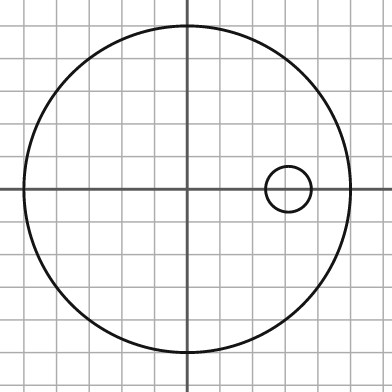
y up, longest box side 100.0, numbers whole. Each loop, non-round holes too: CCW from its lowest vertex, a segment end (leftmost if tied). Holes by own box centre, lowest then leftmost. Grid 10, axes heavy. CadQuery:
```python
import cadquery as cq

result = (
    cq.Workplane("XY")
    .moveTo(0.0, 0.0)
    .circle(50.0)
    .moveTo(31.0, 0.0)
    .circle(7.0)
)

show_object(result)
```